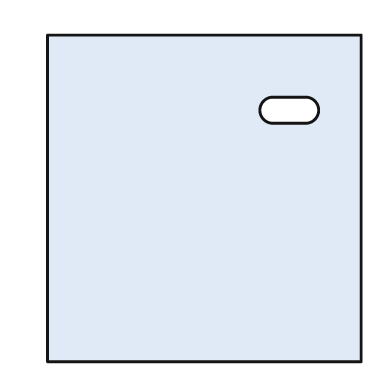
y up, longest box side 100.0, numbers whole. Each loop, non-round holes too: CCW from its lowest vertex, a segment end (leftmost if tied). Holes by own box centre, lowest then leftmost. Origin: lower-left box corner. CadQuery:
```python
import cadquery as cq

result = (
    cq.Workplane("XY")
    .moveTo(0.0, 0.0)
    .lineTo(96.0, 0.0)
    .lineTo(96.0, 100.0)
    .lineTo(0.0, 100.0)
    .close()
    .moveTo(69.0, 73.0)
    .lineTo(79.0, 73.0)
    .threePointArc((83.0, 77.0), (79.0, 81.0))
    .lineTo(69.0, 81.0)
    .threePointArc((65.0, 77.0), (69.0, 73.0))
    .close()
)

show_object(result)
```